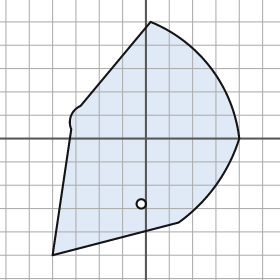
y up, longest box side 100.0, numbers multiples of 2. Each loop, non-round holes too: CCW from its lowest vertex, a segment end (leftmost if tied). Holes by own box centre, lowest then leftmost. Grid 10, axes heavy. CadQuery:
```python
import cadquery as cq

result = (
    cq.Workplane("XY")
    .moveTo(-40.0, -50.0)
    .lineTo(14.0, -36.0)
    .threePointArc((30.0, -20.0), (40.0, 0.0))
    .threePointArc((28.0, 30.0), (2.0, 50.0))
    .lineTo(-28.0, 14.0)
    .threePointArc((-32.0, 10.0), (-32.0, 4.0))
    .close()
    .moveTo(-2.0, -28.0)
    .circle(2.0)
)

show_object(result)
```